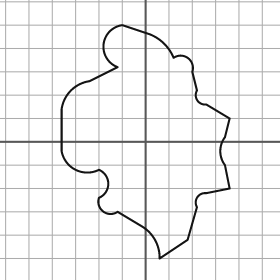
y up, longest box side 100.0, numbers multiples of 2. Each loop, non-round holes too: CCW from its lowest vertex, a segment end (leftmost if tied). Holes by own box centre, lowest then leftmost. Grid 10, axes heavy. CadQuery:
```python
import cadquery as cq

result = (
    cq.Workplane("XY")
    .moveTo(6.0, -50.0)
    .lineTo(18.0, -42.0)
    .lineTo(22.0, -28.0)
    .threePointArc((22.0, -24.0), (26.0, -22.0))
    .lineTo(36.0, -20.0)
    .lineTo(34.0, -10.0)
    .threePointArc((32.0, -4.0), (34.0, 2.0))
    .lineTo(36.0, 10.0)
    .lineTo(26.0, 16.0)
    .threePointArc((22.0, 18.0), (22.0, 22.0))
    .lineTo(20.0, 30.0)
    .threePointArc((18.0, 36.0), (12.0, 36.0))
    .threePointArc((8.0, 42.0), (2.0, 46.0))
    .lineTo(-10.0, 50.0)
    .threePointArc((-18.0, 42.0), (-12.0, 32.0))
    .lineTo(-24.0, 26.0)
    .threePointArc((-32.0, 22.0), (-36.0, 14.0))
    .lineTo(-36.0, -4.0)
    .threePointArc((-30.0, -12.0), (-20.0, -12.0))
    .threePointArc((-16.0, -18.0), (-20.0, -24.0))
    .threePointArc((-18.0, -30.0), (-12.0, -30.0))
    .lineTo(-2.0, -36.0)
    .threePointArc((4.0, -42.0), (6.0, -50.0))
    .close()
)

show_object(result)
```